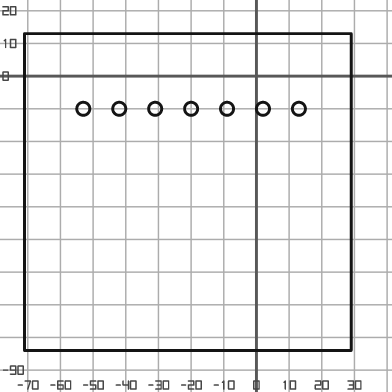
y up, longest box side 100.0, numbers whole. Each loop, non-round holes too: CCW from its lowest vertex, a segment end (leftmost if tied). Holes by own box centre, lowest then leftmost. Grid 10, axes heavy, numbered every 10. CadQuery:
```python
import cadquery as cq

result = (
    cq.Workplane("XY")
    .moveTo(-71.0, -84.0)
    .lineTo(29.0, -84.0)
    .lineTo(29.0, 13.0)
    .lineTo(-71.0, 13.0)
    .close()
    .moveTo(-53.0, -10.0)
    .circle(2.0)
    .moveTo(-42.0, -10.0)
    .circle(2.0)
    .moveTo(-31.0, -10.0)
    .circle(2.0)
    .moveTo(-20.0, -10.0)
    .circle(2.0)
    .moveTo(-9.0, -10.0)
    .circle(2.0)
    .moveTo(2.0, -10.0)
    .circle(2.0)
    .moveTo(13.0, -10.0)
    .circle(2.0)
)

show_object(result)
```